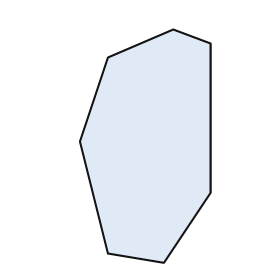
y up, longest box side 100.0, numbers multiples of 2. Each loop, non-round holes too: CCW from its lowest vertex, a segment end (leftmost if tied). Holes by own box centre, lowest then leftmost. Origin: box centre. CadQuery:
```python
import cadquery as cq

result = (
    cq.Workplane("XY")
    .moveTo(8.0, -50.0)
    .lineTo(28.0, -20.0)
    .lineTo(28.0, 44.0)
    .lineTo(12.0, 50.0)
    .lineTo(-16.0, 38.0)
    .lineTo(-28.0, 2.0)
    .lineTo(-16.0, -46.0)
    .close()
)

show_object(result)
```